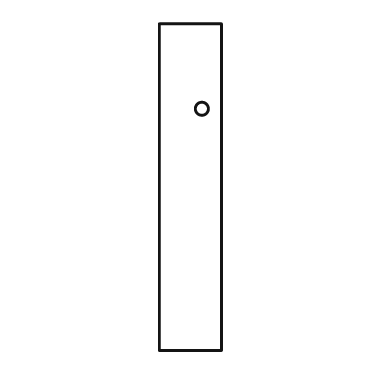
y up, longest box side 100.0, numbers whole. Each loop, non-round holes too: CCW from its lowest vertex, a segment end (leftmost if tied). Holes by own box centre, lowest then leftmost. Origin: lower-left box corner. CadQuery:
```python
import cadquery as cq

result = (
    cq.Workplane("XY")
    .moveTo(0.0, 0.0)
    .lineTo(19.0, 0.0)
    .lineTo(19.0, 100.0)
    .lineTo(0.0, 100.0)
    .close()
    .moveTo(13.0, 74.0)
    .circle(2.0)
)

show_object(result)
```